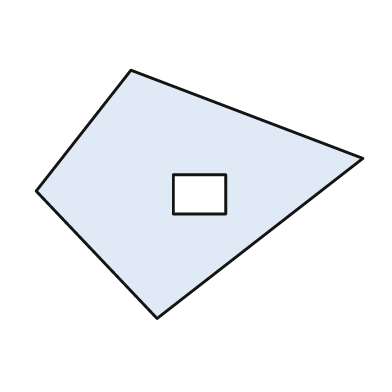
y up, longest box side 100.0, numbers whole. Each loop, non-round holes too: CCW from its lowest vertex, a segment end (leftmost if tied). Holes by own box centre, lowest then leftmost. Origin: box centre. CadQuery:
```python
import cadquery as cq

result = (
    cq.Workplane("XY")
    .moveTo(-13.0, -38.0)
    .lineTo(50.0, 11.0)
    .lineTo(-21.0, 38.0)
    .lineTo(-50.0, 1.0)
    .close()
    .moveTo(-8.0, -6.0)
    .lineTo(8.0, -6.0)
    .lineTo(8.0, 6.0)
    .lineTo(-8.0, 6.0)
    .close()
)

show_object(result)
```